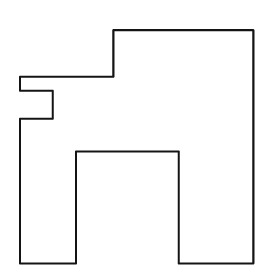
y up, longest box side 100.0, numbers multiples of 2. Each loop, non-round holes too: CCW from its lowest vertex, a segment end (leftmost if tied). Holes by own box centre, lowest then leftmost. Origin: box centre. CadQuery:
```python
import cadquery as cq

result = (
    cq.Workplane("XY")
    .moveTo(-50.0, -50.0)
    .lineTo(-26.0, -50.0)
    .lineTo(-26.0, -2.0)
    .lineTo(18.0, -2.0)
    .lineTo(18.0, -50.0)
    .lineTo(50.0, -50.0)
    .lineTo(50.0, 50.0)
    .lineTo(-10.0, 50.0)
    .lineTo(-10.0, 30.0)
    .lineTo(-50.0, 30.0)
    .lineTo(-50.0, 24.0)
    .lineTo(-36.0, 24.0)
    .lineTo(-36.0, 12.0)
    .lineTo(-50.0, 12.0)
    .close()
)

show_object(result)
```